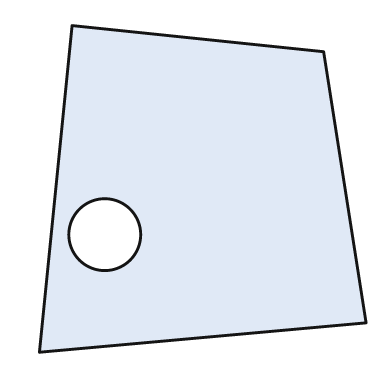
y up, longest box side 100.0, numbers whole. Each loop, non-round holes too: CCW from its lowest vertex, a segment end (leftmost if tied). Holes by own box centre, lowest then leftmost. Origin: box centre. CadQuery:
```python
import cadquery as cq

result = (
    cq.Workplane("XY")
    .moveTo(-50.0, -50.0)
    .lineTo(50.0, -41.0)
    .lineTo(37.0, 42.0)
    .lineTo(-40.0, 50.0)
    .close()
    .moveTo(-30.0, -14.0)
    .circle(11.0)
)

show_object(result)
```